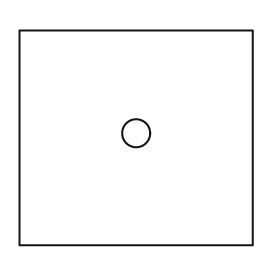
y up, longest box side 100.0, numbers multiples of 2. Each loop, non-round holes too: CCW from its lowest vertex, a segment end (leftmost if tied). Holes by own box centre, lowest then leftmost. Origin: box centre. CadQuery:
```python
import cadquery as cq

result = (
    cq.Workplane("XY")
    .moveTo(-50.0, -46.0)
    .lineTo(50.0, -46.0)
    .lineTo(50.0, 46.0)
    .lineTo(-50.0, 46.0)
    .close()
    .moveTo(0.0, 2.0)
    .circle(6.0)
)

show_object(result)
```